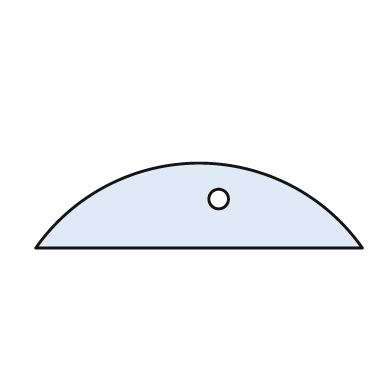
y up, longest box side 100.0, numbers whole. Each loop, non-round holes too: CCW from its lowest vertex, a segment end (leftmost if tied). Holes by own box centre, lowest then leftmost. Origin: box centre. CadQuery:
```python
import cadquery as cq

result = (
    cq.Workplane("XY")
    .moveTo(-50.0, -13.0)
    .lineTo(50.0, -13.0)
    .threePointArc((0.0, 13.0), (-50.0, -13.0))
    .close()
    .moveTo(6.0, 2.0)
    .circle(3.0)
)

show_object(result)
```